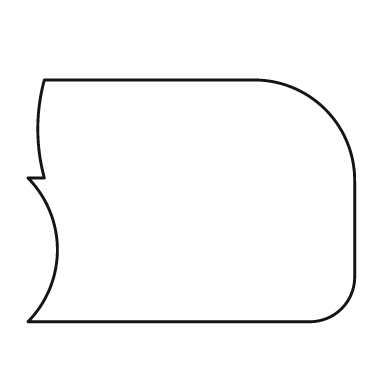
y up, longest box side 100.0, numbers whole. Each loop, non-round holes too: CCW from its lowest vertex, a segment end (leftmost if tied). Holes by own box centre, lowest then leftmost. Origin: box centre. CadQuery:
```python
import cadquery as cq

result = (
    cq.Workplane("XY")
    .moveTo(-50.0, -37.0)
    .lineTo(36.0, -37.0)
    .threePointArc((46.0, -33.0), (50.0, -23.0))
    .lineTo(50.0, 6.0)
    .threePointArc((41.0, 28.0), (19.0, 37.0))
    .lineTo(-45.0, 37.0)
    .threePointArc((-47.0, 22.0), (-45.0, 7.0))
    .lineTo(-50.0, 7.0)
    .threePointArc((-41.0, -15.0), (-50.0, -37.0))
    .close()
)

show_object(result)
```